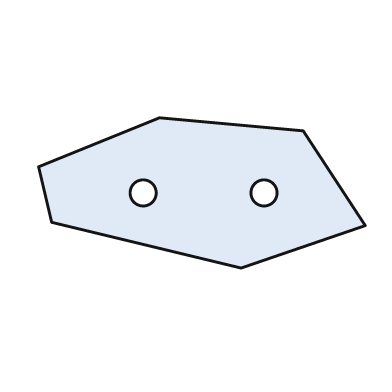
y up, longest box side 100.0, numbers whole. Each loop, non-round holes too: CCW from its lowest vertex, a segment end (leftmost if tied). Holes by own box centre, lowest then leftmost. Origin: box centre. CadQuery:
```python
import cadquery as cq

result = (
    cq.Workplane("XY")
    .moveTo(12.0, -23.0)
    .lineTo(50.0, -10.0)
    .lineTo(31.0, 19.0)
    .lineTo(-13.0, 23.0)
    .lineTo(-50.0, 8.0)
    .lineTo(-46.0, -9.0)
    .close()
    .moveTo(-18.0, 0.0)
    .circle(4.0)
    .moveTo(19.0, 0.0)
    .circle(4.0)
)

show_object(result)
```